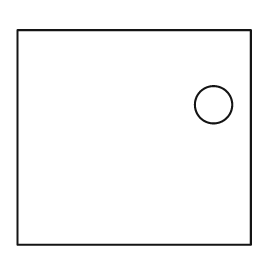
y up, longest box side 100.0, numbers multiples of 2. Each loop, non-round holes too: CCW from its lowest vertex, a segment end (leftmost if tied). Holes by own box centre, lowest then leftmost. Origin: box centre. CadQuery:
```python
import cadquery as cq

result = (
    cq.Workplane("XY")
    .moveTo(-50.0, -46.0)
    .lineTo(50.0, -46.0)
    .lineTo(50.0, 46.0)
    .lineTo(-50.0, 46.0)
    .close()
    .moveTo(34.0, 14.0)
    .circle(8.0)
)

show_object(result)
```